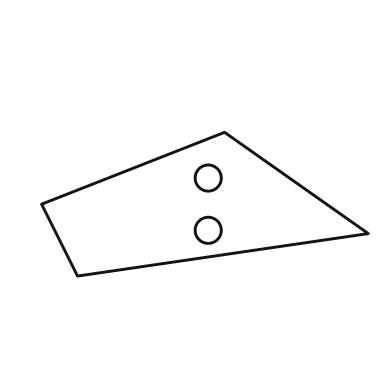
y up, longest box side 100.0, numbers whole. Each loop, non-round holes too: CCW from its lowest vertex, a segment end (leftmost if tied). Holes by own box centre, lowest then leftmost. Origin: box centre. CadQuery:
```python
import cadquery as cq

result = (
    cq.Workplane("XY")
    .moveTo(-39.0, -22.0)
    .lineTo(50.0, -9.0)
    .lineTo(6.0, 22.0)
    .lineTo(-50.0, 0.0)
    .close()
    .moveTo(1.0, -8.0)
    .circle(4.0)
    .moveTo(1.0, 8.0)
    .circle(4.0)
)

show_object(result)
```